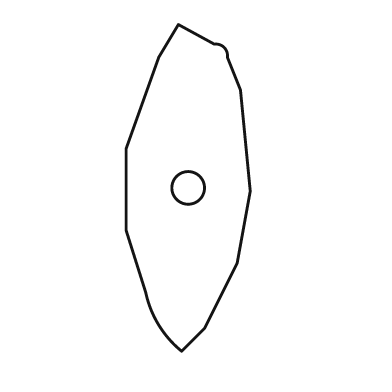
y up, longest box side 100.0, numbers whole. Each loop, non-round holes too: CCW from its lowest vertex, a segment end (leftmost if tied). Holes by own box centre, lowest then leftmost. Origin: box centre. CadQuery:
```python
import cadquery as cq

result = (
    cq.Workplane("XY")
    .moveTo(-2.0, -50.0)
    .lineTo(5.0, -43.0)
    .lineTo(15.0, -23.0)
    .lineTo(19.0, -1.0)
    .lineTo(16.0, 30.0)
    .lineTo(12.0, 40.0)
    .threePointArc((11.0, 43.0), (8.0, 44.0))
    .lineTo(-3.0, 50.0)
    .lineTo(-9.0, 40.0)
    .lineTo(-19.0, 12.0)
    .lineTo(-19.0, -13.0)
    .lineTo(-13.0, -32.0)
    .threePointArc((-9.0, -42.0), (-2.0, -50.0))
    .close()
    .moveTo(0.0, 0.0)
    .circle(5.0)
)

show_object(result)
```